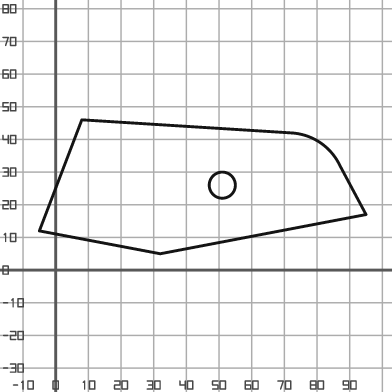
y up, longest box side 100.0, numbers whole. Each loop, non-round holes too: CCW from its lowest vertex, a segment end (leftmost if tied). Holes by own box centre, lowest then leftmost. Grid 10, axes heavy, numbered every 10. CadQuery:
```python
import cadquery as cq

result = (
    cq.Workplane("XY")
    .moveTo(32.0, 5.0)
    .lineTo(95.0, 17.0)
    .lineTo(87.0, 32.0)
    .threePointArc((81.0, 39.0), (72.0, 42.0))
    .lineTo(8.0, 46.0)
    .lineTo(-5.0, 12.0)
    .close()
    .moveTo(51.0, 26.0)
    .circle(4.0)
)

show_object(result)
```